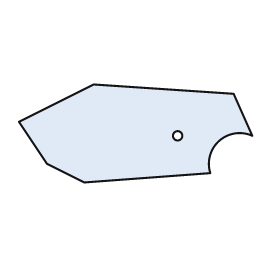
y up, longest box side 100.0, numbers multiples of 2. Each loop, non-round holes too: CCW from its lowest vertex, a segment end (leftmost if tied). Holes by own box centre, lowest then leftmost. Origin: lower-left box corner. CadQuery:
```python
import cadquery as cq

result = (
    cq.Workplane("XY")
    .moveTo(28.0, 0.0)
    .lineTo(82.0, 4.0)
    .threePointArc((86.0, 18.0), (100.0, 20.0))
    .lineTo(92.0, 38.0)
    .lineTo(32.0, 42.0)
    .lineTo(0.0, 26.0)
    .lineTo(12.0, 8.0)
    .close()
    .moveTo(68.0, 20.0)
    .circle(2.0)
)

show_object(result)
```